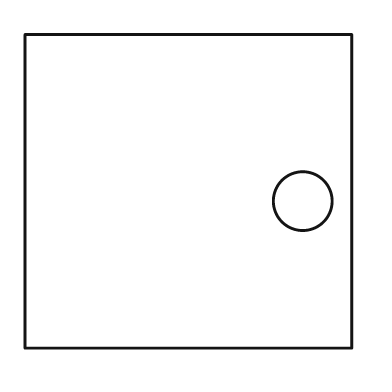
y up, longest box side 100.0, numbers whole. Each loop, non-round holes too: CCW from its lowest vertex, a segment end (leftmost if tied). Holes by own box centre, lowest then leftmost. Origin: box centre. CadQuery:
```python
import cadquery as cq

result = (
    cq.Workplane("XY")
    .moveTo(-50.0, -48.0)
    .lineTo(50.0, -48.0)
    .lineTo(50.0, 48.0)
    .lineTo(-50.0, 48.0)
    .close()
    .moveTo(35.0, -3.0)
    .circle(9.0)
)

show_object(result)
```